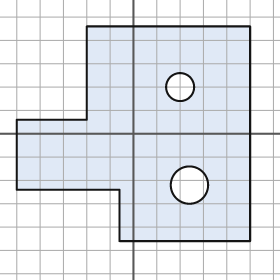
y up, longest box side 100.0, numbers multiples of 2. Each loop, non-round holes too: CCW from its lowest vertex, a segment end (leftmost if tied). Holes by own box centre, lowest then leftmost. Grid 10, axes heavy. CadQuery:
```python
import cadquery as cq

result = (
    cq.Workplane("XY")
    .moveTo(-6.0, -46.0)
    .lineTo(50.0, -46.0)
    .lineTo(50.0, 46.0)
    .lineTo(-20.0, 46.0)
    .lineTo(-20.0, 6.0)
    .lineTo(-50.0, 6.0)
    .lineTo(-50.0, -24.0)
    .lineTo(-6.0, -24.0)
    .close()
    .moveTo(24.0, -22.0)
    .circle(8.0)
    .moveTo(20.0, 20.0)
    .circle(6.0)
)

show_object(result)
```